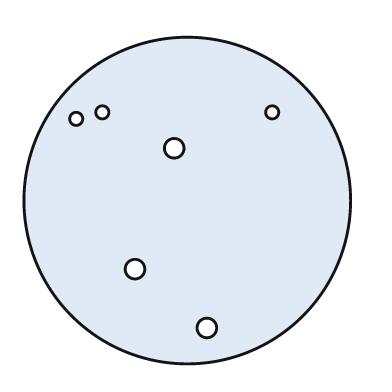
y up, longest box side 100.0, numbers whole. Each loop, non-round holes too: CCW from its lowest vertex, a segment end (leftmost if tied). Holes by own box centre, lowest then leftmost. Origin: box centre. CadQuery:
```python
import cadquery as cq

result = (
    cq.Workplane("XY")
    .moveTo(0.0, 0.0)
    .circle(50.0)
    .moveTo(6.0, -39.0)
    .circle(3.0)
    .moveTo(-16.0, -21.0)
    .circle(3.0)
    .moveTo(-4.0, 16.0)
    .circle(3.0)
    .moveTo(-34.0, 25.0)
    .circle(2.0)
    .moveTo(-26.0, 27.0)
    .circle(2.0)
    .moveTo(26.0, 27.0)
    .circle(2.0)
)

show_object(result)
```